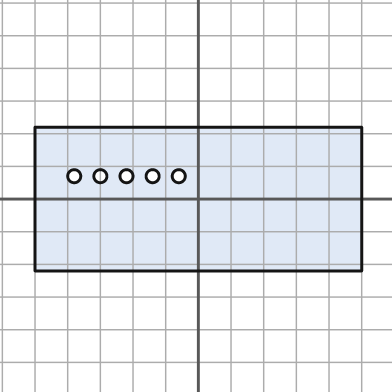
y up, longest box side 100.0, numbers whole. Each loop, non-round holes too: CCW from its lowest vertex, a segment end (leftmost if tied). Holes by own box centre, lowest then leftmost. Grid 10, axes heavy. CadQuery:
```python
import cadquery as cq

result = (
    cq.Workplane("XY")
    .moveTo(-50.0, -22.0)
    .lineTo(50.0, -22.0)
    .lineTo(50.0, 22.0)
    .lineTo(-50.0, 22.0)
    .close()
    .moveTo(-38.0, 7.0)
    .circle(2.0)
    .moveTo(-30.0, 7.0)
    .circle(2.0)
    .moveTo(-22.0, 7.0)
    .circle(2.0)
    .moveTo(-14.0, 7.0)
    .circle(2.0)
    .moveTo(-6.0, 7.0)
    .circle(2.0)
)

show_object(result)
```